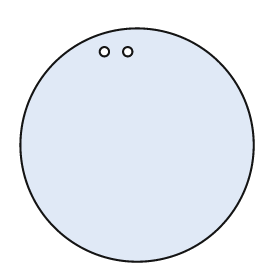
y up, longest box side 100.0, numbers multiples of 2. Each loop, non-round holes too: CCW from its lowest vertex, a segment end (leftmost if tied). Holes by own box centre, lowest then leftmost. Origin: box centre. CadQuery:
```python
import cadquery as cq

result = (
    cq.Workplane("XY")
    .moveTo(0.0, 0.0)
    .circle(50.0)
    .moveTo(-14.0, 40.0)
    .circle(2.0)
    .moveTo(-4.0, 40.0)
    .circle(2.0)
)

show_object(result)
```